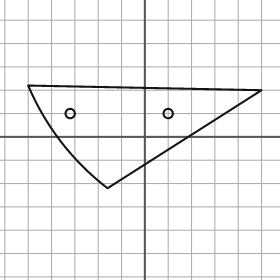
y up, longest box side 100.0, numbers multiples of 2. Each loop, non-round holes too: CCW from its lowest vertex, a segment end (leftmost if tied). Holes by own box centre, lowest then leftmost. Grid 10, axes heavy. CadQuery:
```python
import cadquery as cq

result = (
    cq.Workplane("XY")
    .moveTo(-16.0, -22.0)
    .lineTo(50.0, 20.0)
    .lineTo(-50.0, 22.0)
    .threePointArc((-36.0, -2.0), (-16.0, -22.0))
    .close()
    .moveTo(-32.0, 10.0)
    .circle(2.0)
    .moveTo(10.0, 10.0)
    .circle(2.0)
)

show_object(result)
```